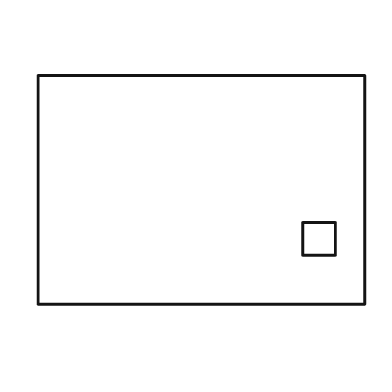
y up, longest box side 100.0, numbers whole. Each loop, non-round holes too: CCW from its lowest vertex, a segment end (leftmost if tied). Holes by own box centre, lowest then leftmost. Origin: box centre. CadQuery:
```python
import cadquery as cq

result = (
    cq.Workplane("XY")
    .moveTo(-50.0, -35.0)
    .lineTo(50.0, -35.0)
    .lineTo(50.0, 35.0)
    .lineTo(-50.0, 35.0)
    .close()
    .moveTo(31.0, -20.0)
    .lineTo(41.0, -20.0)
    .lineTo(41.0, -10.0)
    .lineTo(31.0, -10.0)
    .close()
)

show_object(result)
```